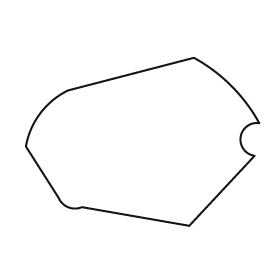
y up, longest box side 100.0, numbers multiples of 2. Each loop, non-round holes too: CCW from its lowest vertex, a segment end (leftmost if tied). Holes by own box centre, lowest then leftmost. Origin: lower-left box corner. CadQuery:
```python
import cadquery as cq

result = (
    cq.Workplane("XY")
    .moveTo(70.0, 0.0)
    .lineTo(98.0, 30.0)
    .threePointArc((92.0, 38.0), (100.0, 44.0))
    .threePointArc((88.0, 60.0), (72.0, 72.0))
    .lineTo(18.0, 58.0)
    .threePointArc((6.0, 48.0), (0.0, 34.0))
    .lineTo(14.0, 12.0)
    .threePointArc((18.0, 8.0), (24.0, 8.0))
    .close()
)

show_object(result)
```